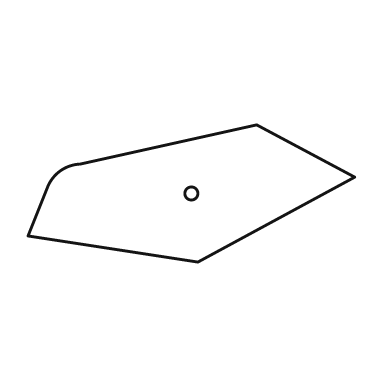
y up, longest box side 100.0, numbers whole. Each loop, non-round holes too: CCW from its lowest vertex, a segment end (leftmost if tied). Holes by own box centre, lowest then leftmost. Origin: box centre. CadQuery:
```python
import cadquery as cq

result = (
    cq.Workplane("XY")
    .moveTo(2.0, -21.0)
    .lineTo(50.0, 5.0)
    .lineTo(20.0, 21.0)
    .lineTo(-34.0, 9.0)
    .threePointArc((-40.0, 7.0), (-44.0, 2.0))
    .lineTo(-50.0, -13.0)
    .close()
    .moveTo(0.0, 0.0)
    .circle(2.0)
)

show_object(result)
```